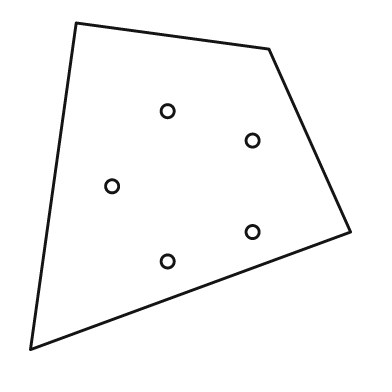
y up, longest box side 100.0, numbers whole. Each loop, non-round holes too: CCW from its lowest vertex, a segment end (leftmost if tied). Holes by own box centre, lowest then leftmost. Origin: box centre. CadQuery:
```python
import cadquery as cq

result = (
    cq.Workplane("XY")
    .moveTo(-49.0, -50.0)
    .lineTo(49.0, -14.0)
    .lineTo(24.0, 42.0)
    .lineTo(-35.0, 50.0)
    .close()
    .moveTo(-7.0, -23.0)
    .circle(2.0)
    .moveTo(19.0, -14.0)
    .circle(2.0)
    .moveTo(-24.0, 0.0)
    .circle(2.0)
    .moveTo(19.0, 14.0)
    .circle(2.0)
    .moveTo(-7.0, 23.0)
    .circle(2.0)
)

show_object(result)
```